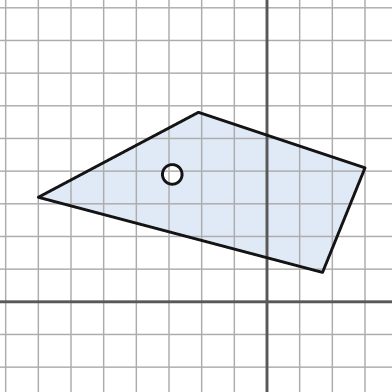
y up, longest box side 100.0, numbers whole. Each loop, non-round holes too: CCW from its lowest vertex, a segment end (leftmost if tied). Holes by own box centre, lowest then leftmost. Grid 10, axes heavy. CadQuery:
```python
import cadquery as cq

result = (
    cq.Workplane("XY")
    .moveTo(17.0, 9.0)
    .lineTo(30.0, 41.0)
    .lineTo(-21.0, 58.0)
    .lineTo(-70.0, 32.0)
    .close()
    .moveTo(-29.0, 39.0)
    .circle(3.0)
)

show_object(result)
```